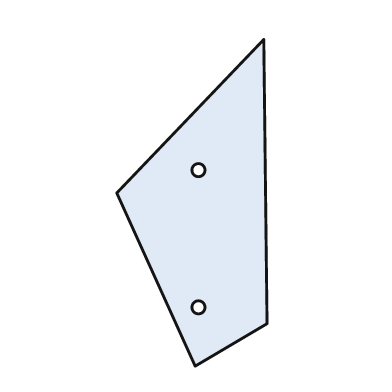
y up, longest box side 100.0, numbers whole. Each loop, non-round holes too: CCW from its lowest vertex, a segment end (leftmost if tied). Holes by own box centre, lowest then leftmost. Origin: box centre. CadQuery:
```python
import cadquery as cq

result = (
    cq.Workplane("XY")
    .moveTo(1.0, -50.0)
    .lineTo(23.0, -37.0)
    .lineTo(22.0, 50.0)
    .lineTo(-23.0, 3.0)
    .close()
    .moveTo(2.0, -32.0)
    .circle(2.0)
    .moveTo(2.0, 10.0)
    .circle(2.0)
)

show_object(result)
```